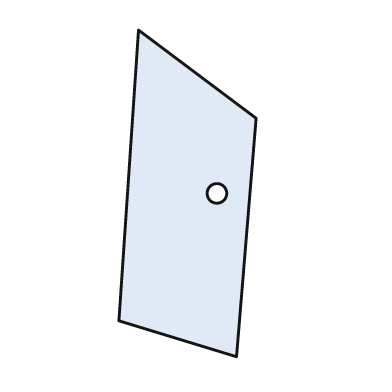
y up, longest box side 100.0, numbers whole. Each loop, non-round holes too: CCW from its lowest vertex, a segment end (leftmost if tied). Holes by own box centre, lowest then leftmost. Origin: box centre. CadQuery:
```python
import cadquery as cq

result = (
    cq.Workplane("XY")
    .moveTo(15.0, -50.0)
    .lineTo(21.0, 23.0)
    .lineTo(-15.0, 50.0)
    .lineTo(-21.0, -39.0)
    .close()
    .moveTo(9.0, 0.0)
    .circle(3.0)
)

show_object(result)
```